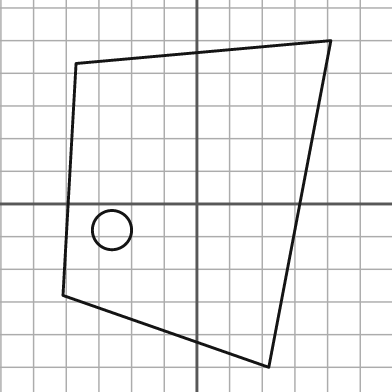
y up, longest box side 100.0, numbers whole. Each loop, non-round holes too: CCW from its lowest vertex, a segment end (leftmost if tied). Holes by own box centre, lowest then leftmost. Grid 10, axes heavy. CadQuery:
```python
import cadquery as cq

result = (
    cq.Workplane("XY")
    .moveTo(22.0, -50.0)
    .lineTo(41.0, 50.0)
    .lineTo(-37.0, 43.0)
    .lineTo(-41.0, -28.0)
    .close()
    .moveTo(-26.0, -8.0)
    .circle(6.0)
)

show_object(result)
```